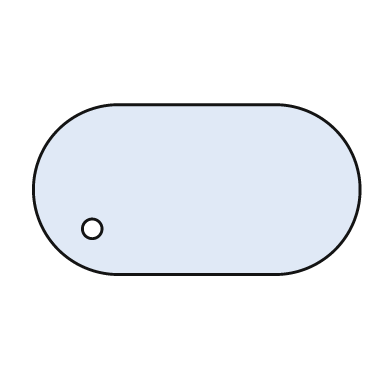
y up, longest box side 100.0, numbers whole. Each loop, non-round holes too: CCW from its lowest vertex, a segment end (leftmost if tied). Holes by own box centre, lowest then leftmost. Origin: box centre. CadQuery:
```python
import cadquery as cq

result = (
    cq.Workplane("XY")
    .moveTo(-24.0, -26.0)
    .lineTo(24.0, -26.0)
    .threePointArc((50.0, 0.0), (24.0, 26.0))
    .lineTo(-24.0, 26.0)
    .threePointArc((-50.0, 0.0), (-24.0, -26.0))
    .close()
    .moveTo(-32.0, -12.0)
    .circle(3.0)
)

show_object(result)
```